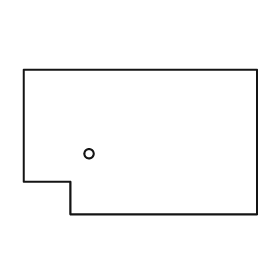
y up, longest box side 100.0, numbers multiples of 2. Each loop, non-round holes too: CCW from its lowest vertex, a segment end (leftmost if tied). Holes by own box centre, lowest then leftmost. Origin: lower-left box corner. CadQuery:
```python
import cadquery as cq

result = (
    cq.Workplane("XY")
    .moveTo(20.0, 0.0)
    .lineTo(100.0, 0.0)
    .lineTo(100.0, 62.0)
    .lineTo(0.0, 62.0)
    .lineTo(0.0, 14.0)
    .lineTo(20.0, 14.0)
    .close()
    .moveTo(28.0, 26.0)
    .circle(2.0)
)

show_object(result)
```